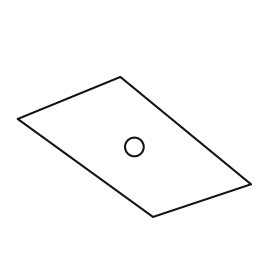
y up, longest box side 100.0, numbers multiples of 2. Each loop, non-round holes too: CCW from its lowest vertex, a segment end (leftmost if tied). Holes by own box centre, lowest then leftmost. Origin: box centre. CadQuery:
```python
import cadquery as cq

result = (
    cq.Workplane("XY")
    .moveTo(8.0, -30.0)
    .lineTo(50.0, -16.0)
    .lineTo(-6.0, 30.0)
    .lineTo(-50.0, 12.0)
    .close()
    .moveTo(0.0, 0.0)
    .circle(4.0)
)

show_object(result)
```